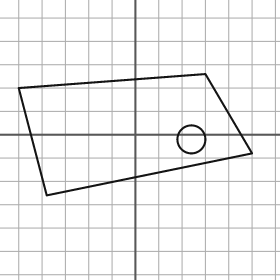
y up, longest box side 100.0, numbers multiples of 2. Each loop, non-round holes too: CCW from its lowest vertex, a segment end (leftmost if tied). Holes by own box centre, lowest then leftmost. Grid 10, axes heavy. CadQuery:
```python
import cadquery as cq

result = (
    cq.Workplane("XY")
    .moveTo(-38.0, -26.0)
    .lineTo(50.0, -8.0)
    .lineTo(30.0, 26.0)
    .lineTo(-50.0, 20.0)
    .close()
    .moveTo(24.0, -2.0)
    .circle(6.0)
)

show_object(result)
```